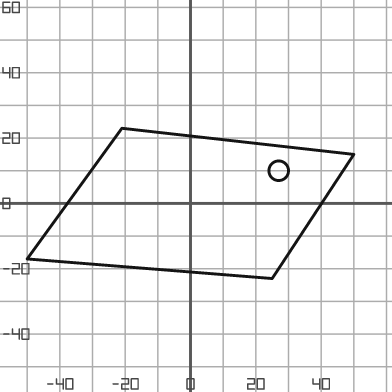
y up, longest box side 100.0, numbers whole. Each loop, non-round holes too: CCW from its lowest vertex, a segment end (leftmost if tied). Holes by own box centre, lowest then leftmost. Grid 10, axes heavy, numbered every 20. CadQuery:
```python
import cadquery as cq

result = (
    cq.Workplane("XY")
    .moveTo(25.0, -23.0)
    .lineTo(50.0, 15.0)
    .lineTo(-21.0, 23.0)
    .lineTo(-50.0, -17.0)
    .close()
    .moveTo(27.0, 10.0)
    .circle(3.0)
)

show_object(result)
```